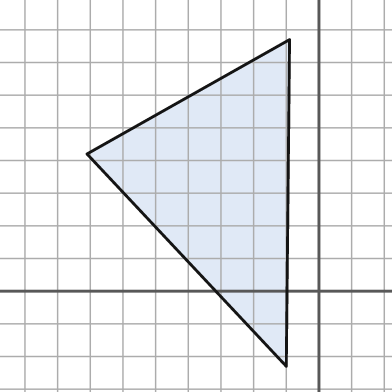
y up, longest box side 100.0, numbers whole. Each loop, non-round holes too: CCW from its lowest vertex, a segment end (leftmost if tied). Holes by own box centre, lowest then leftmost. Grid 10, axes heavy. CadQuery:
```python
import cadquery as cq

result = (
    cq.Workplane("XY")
    .moveTo(-10.0, -23.0)
    .lineTo(-9.0, 77.0)
    .lineTo(-71.0, 42.0)
    .close()
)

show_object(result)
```